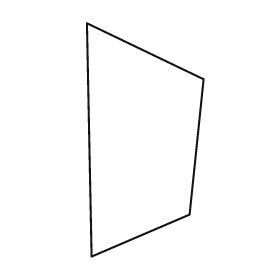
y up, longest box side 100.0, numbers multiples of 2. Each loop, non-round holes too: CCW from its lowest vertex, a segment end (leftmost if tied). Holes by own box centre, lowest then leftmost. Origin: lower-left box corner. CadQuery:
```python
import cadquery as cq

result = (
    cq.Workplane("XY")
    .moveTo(2.0, 0.0)
    .lineTo(44.0, 18.0)
    .lineTo(50.0, 76.0)
    .lineTo(0.0, 100.0)
    .close()
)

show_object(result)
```